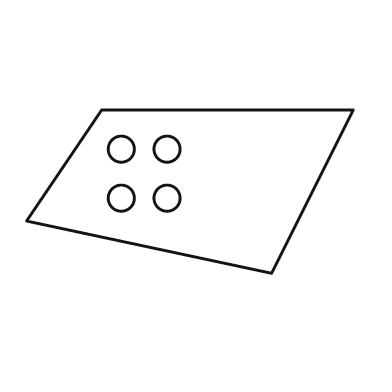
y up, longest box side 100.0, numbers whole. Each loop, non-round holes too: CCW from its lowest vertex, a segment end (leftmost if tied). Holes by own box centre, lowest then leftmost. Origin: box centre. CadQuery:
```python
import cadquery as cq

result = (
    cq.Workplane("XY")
    .moveTo(25.0, -25.0)
    .lineTo(50.0, 25.0)
    .lineTo(-27.0, 25.0)
    .lineTo(-50.0, -9.0)
    .close()
    .moveTo(-21.0, -2.0)
    .circle(4.0)
    .moveTo(-7.0, -2.0)
    .circle(4.0)
    .moveTo(-21.0, 13.0)
    .circle(4.0)
    .moveTo(-7.0, 13.0)
    .circle(4.0)
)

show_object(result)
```